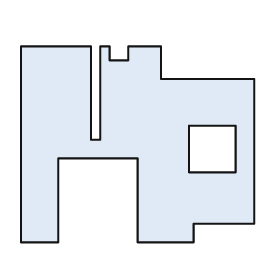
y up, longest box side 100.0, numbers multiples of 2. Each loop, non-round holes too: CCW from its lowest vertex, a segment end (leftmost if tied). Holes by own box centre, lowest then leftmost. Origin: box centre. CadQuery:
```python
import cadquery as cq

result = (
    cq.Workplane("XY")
    .moveTo(-50.0, -42.0)
    .lineTo(-34.0, -42.0)
    .lineTo(-34.0, -6.0)
    .lineTo(0.0, -6.0)
    .lineTo(0.0, -42.0)
    .lineTo(24.0, -42.0)
    .lineTo(24.0, -34.0)
    .lineTo(50.0, -34.0)
    .lineTo(50.0, 28.0)
    .lineTo(10.0, 28.0)
    .lineTo(10.0, 42.0)
    .lineTo(-4.0, 42.0)
    .lineTo(-4.0, 36.0)
    .lineTo(-12.0, 36.0)
    .lineTo(-12.0, 42.0)
    .lineTo(-16.0, 42.0)
    .lineTo(-16.0, 2.0)
    .lineTo(-20.0, 2.0)
    .lineTo(-20.0, 42.0)
    .lineTo(-50.0, 42.0)
    .close()
    .moveTo(22.0, -12.0)
    .lineTo(42.0, -12.0)
    .lineTo(42.0, 8.0)
    .lineTo(22.0, 8.0)
    .close()
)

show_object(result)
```